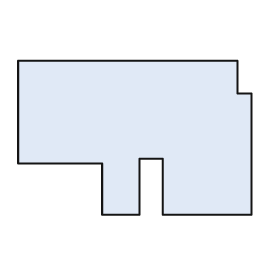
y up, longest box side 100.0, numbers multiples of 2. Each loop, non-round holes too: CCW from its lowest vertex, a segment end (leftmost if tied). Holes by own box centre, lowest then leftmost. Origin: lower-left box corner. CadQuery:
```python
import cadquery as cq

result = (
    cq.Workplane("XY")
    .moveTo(36.0, 0.0)
    .lineTo(52.0, 0.0)
    .lineTo(52.0, 24.0)
    .lineTo(62.0, 24.0)
    .lineTo(62.0, 0.0)
    .lineTo(100.0, 0.0)
    .lineTo(100.0, 52.0)
    .lineTo(94.0, 52.0)
    .lineTo(94.0, 66.0)
    .lineTo(0.0, 66.0)
    .lineTo(0.0, 22.0)
    .lineTo(36.0, 22.0)
    .close()
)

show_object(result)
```